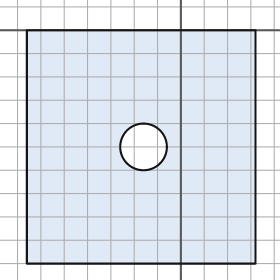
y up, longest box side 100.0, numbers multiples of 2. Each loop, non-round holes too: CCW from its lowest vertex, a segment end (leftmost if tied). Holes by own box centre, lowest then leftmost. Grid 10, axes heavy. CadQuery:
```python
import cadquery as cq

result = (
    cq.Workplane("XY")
    .moveTo(-66.0, -100.0)
    .lineTo(32.0, -100.0)
    .lineTo(32.0, 0.0)
    .lineTo(-66.0, 0.0)
    .close()
    .moveTo(-16.0, -50.0)
    .circle(10.0)
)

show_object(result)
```